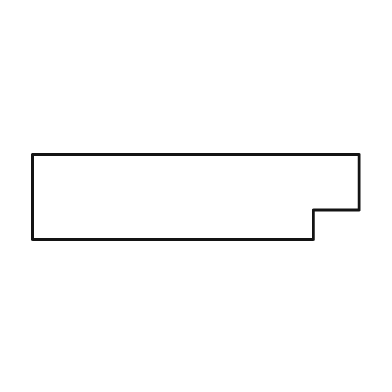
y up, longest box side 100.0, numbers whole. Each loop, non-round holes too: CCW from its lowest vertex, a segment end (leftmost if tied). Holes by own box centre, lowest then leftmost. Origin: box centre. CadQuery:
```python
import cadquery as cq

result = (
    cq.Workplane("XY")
    .moveTo(-50.0, -13.0)
    .lineTo(36.0, -13.0)
    .lineTo(36.0, -4.0)
    .lineTo(50.0, -4.0)
    .lineTo(50.0, 13.0)
    .lineTo(-50.0, 13.0)
    .close()
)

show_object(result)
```